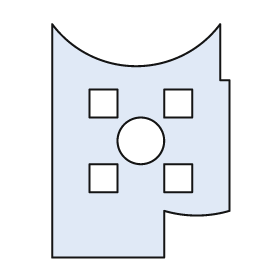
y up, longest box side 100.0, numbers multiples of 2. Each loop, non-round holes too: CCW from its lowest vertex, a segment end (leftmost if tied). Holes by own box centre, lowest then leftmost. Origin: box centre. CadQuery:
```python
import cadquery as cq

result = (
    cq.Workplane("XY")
    .moveTo(-38.0, -50.0)
    .lineTo(10.0, -50.0)
    .lineTo(10.0, -30.0)
    .threePointArc((24.0, -32.0), (38.0, -30.0))
    .lineTo(38.0, 26.0)
    .lineTo(34.0, 26.0)
    .lineTo(34.0, 50.0)
    .threePointArc((-2.0, 32.0), (-38.0, 50.0))
    .close()
    .moveTo(-22.0, -22.0)
    .lineTo(-10.0, -22.0)
    .lineTo(-10.0, -10.0)
    .lineTo(-22.0, -10.0)
    .close()
    .moveTo(10.0, -22.0)
    .lineTo(22.0, -22.0)
    .lineTo(22.0, -10.0)
    .lineTo(10.0, -10.0)
    .close()
    .moveTo(0.0, 0.0)
    .circle(10.0)
    .moveTo(-22.0, 10.0)
    .lineTo(-10.0, 10.0)
    .lineTo(-10.0, 22.0)
    .lineTo(-22.0, 22.0)
    .close()
    .moveTo(10.0, 10.0)
    .lineTo(22.0, 10.0)
    .lineTo(22.0, 22.0)
    .lineTo(10.0, 22.0)
    .close()
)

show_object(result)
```